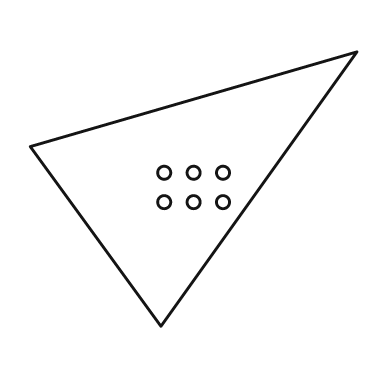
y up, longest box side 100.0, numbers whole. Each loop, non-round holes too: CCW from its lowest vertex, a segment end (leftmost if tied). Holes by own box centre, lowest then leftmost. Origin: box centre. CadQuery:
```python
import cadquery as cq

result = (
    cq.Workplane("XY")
    .moveTo(-10.0, -42.0)
    .lineTo(50.0, 42.0)
    .lineTo(-50.0, 13.0)
    .close()
    .moveTo(-9.0, -4.0)
    .circle(2.0)
    .moveTo(0.0, -4.0)
    .circle(2.0)
    .moveTo(9.0, -4.0)
    .circle(2.0)
    .moveTo(-9.0, 5.0)
    .circle(2.0)
    .moveTo(0.0, 5.0)
    .circle(2.0)
    .moveTo(9.0, 5.0)
    .circle(2.0)
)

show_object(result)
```